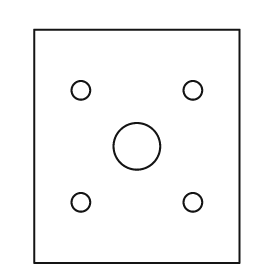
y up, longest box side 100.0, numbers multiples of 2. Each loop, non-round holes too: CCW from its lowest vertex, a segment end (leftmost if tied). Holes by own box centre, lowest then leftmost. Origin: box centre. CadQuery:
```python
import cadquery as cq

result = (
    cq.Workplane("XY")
    .moveTo(-44.0, -50.0)
    .lineTo(44.0, -50.0)
    .lineTo(44.0, 50.0)
    .lineTo(-44.0, 50.0)
    .close()
    .moveTo(-24.0, -24.0)
    .circle(4.0)
    .moveTo(24.0, -24.0)
    .circle(4.0)
    .moveTo(0.0, 0.0)
    .circle(10.0)
    .moveTo(-24.0, 24.0)
    .circle(4.0)
    .moveTo(24.0, 24.0)
    .circle(4.0)
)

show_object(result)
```